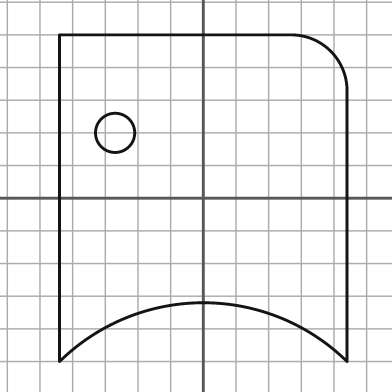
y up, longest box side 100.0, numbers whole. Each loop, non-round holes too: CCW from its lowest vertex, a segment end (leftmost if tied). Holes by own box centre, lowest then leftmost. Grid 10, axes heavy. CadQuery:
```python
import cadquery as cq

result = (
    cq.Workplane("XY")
    .moveTo(-44.0, -50.0)
    .threePointArc((0.0, -32.0), (44.0, -50.0))
    .lineTo(44.0, 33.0)
    .threePointArc((39.0, 45.0), (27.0, 50.0))
    .lineTo(-44.0, 50.0)
    .close()
    .moveTo(-27.0, 20.0)
    .circle(6.0)
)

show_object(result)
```